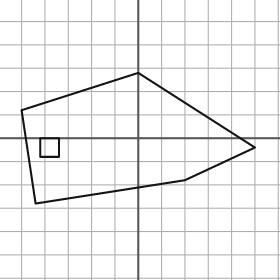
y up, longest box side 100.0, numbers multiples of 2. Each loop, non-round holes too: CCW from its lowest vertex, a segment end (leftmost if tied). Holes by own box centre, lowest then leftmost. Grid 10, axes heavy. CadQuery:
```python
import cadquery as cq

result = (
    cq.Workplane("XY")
    .moveTo(-44.0, -28.0)
    .lineTo(20.0, -18.0)
    .lineTo(50.0, -4.0)
    .lineTo(0.0, 28.0)
    .lineTo(-50.0, 12.0)
    .close()
    .moveTo(-42.0, -8.0)
    .lineTo(-34.0, -8.0)
    .lineTo(-34.0, 0.0)
    .lineTo(-42.0, 0.0)
    .close()
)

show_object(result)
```